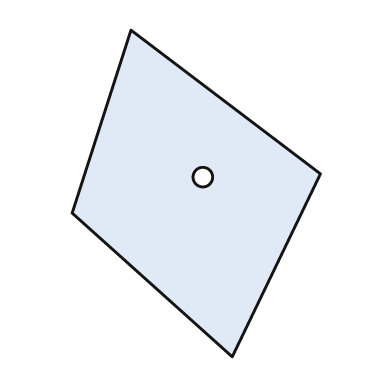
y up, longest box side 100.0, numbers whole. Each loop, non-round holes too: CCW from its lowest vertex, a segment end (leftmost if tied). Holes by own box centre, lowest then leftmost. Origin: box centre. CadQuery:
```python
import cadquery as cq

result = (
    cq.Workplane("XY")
    .moveTo(11.0, -50.0)
    .lineTo(38.0, 6.0)
    .lineTo(-20.0, 50.0)
    .lineTo(-38.0, -6.0)
    .close()
    .moveTo(2.0, 5.0)
    .circle(3.0)
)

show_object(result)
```